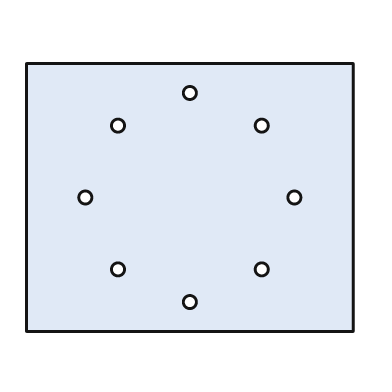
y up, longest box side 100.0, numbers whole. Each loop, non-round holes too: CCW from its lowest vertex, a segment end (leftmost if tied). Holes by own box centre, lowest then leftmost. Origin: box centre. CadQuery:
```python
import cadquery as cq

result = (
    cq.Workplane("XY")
    .moveTo(-50.0, -41.0)
    .lineTo(50.0, -41.0)
    .lineTo(50.0, 41.0)
    .lineTo(-50.0, 41.0)
    .close()
    .moveTo(0.0, -32.0)
    .circle(2.0)
    .moveTo(-22.0, -22.0)
    .circle(2.0)
    .moveTo(22.0, -22.0)
    .circle(2.0)
    .moveTo(-32.0, 0.0)
    .circle(2.0)
    .moveTo(32.0, 0.0)
    .circle(2.0)
    .moveTo(-22.0, 22.0)
    .circle(2.0)
    .moveTo(22.0, 22.0)
    .circle(2.0)
    .moveTo(0.0, 32.0)
    .circle(2.0)
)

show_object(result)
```